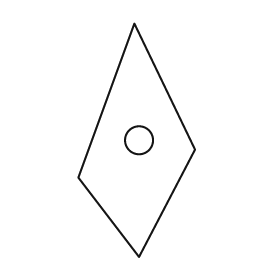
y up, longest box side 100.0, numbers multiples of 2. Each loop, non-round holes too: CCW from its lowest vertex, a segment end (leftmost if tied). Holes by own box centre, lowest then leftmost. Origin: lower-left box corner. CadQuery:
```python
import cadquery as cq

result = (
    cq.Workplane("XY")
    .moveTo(26.0, 0.0)
    .lineTo(50.0, 46.0)
    .lineTo(24.0, 100.0)
    .lineTo(0.0, 34.0)
    .close()
    .moveTo(26.0, 50.0)
    .circle(6.0)
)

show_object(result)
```